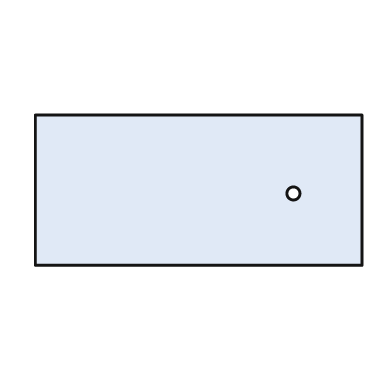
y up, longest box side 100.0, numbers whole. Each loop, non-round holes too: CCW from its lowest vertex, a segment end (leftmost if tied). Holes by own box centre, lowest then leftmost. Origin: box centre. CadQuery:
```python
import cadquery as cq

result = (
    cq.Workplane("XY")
    .moveTo(-50.0, -23.0)
    .lineTo(50.0, -23.0)
    .lineTo(50.0, 23.0)
    .lineTo(-50.0, 23.0)
    .close()
    .moveTo(29.0, -1.0)
    .circle(2.0)
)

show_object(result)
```